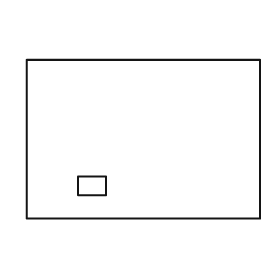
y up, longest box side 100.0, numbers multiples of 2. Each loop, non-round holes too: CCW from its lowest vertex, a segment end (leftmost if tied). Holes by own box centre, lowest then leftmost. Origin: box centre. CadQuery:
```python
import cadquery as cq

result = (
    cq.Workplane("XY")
    .moveTo(-50.0, -34.0)
    .lineTo(50.0, -34.0)
    .lineTo(50.0, 34.0)
    .lineTo(-50.0, 34.0)
    .close()
    .moveTo(-28.0, -24.0)
    .lineTo(-16.0, -24.0)
    .lineTo(-16.0, -16.0)
    .lineTo(-28.0, -16.0)
    .close()
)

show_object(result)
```